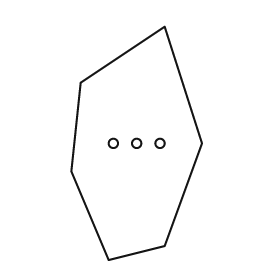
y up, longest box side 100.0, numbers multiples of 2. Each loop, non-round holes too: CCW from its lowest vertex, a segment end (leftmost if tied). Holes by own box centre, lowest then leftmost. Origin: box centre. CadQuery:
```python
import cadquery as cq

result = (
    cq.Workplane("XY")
    .moveTo(-12.0, -50.0)
    .lineTo(12.0, -44.0)
    .lineTo(28.0, 0.0)
    .lineTo(12.0, 50.0)
    .lineTo(-24.0, 26.0)
    .lineTo(-28.0, -12.0)
    .close()
    .moveTo(-10.0, 0.0)
    .circle(2.0)
    .moveTo(0.0, 0.0)
    .circle(2.0)
    .moveTo(10.0, 0.0)
    .circle(2.0)
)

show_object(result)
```